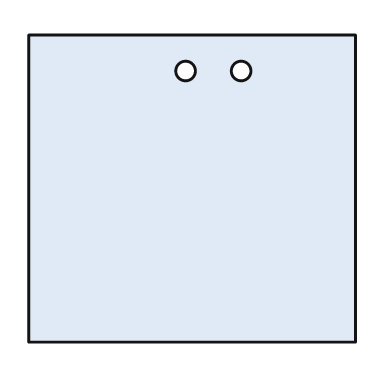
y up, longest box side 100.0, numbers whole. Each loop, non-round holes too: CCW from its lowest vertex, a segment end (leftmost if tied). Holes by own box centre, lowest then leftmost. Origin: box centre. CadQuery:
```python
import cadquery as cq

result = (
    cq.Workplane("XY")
    .moveTo(-50.0, -47.0)
    .lineTo(50.0, -47.0)
    .lineTo(50.0, 47.0)
    .lineTo(-50.0, 47.0)
    .close()
    .moveTo(-2.0, 36.0)
    .circle(3.0)
    .moveTo(15.0, 36.0)
    .circle(3.0)
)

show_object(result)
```